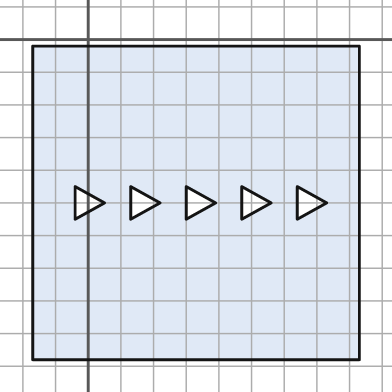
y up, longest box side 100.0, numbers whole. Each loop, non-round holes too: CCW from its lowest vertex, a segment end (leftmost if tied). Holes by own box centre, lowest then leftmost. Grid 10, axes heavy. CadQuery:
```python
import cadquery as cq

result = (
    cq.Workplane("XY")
    .moveTo(-17.0, -98.0)
    .lineTo(83.0, -98.0)
    .lineTo(83.0, -2.0)
    .lineTo(-17.0, -2.0)
    .close()
    .moveTo(-4.0, -55.0)
    .lineTo(5.0, -50.0)
    .lineTo(-4.0, -45.0)
    .close()
    .moveTo(13.0, -55.0)
    .lineTo(22.0, -50.0)
    .lineTo(13.0, -45.0)
    .close()
    .moveTo(30.0, -55.0)
    .lineTo(39.0, -50.0)
    .lineTo(30.0, -45.0)
    .close()
    .moveTo(47.0, -55.0)
    .lineTo(56.0, -50.0)
    .lineTo(47.0, -45.0)
    .close()
    .moveTo(64.0, -55.0)
    .lineTo(73.0, -50.0)
    .lineTo(64.0, -45.0)
    .close()
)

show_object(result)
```